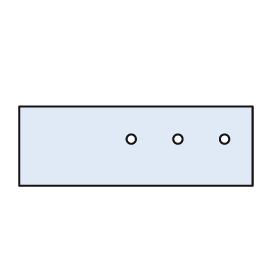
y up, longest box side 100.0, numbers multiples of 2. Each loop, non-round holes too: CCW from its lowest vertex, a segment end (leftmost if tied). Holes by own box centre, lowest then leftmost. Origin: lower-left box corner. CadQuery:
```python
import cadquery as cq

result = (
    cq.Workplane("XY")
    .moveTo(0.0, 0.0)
    .lineTo(100.0, 0.0)
    .lineTo(100.0, 34.0)
    .lineTo(0.0, 34.0)
    .close()
    .moveTo(48.0, 20.0)
    .circle(2.0)
    .moveTo(68.0, 20.0)
    .circle(2.0)
    .moveTo(88.0, 20.0)
    .circle(2.0)
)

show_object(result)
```